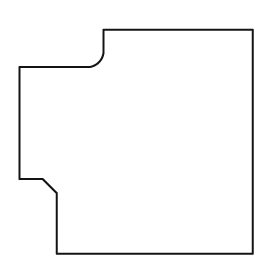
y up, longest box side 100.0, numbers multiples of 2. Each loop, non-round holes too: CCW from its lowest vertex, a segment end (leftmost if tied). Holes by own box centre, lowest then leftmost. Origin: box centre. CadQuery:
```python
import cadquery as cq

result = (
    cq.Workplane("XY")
    .moveTo(-34.0, -48.0)
    .lineTo(50.0, -48.0)
    .lineTo(50.0, 48.0)
    .lineTo(-14.0, 48.0)
    .lineTo(-14.0, 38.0)
    .threePointArc((-16.0, 34.0), (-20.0, 32.0))
    .lineTo(-50.0, 32.0)
    .lineTo(-50.0, -16.0)
    .lineTo(-40.0, -16.0)
    .lineTo(-34.0, -22.0)
    .close()
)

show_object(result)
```